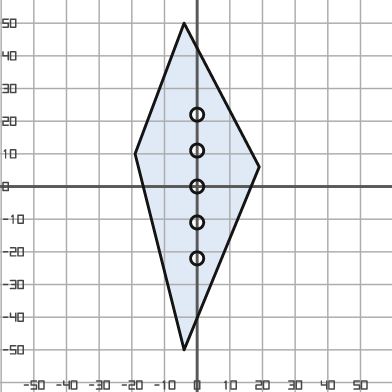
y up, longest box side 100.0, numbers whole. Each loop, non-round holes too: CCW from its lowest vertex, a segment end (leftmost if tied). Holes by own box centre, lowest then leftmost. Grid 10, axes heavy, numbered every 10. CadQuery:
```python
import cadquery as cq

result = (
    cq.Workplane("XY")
    .moveTo(-4.0, -50.0)
    .lineTo(19.0, 6.0)
    .lineTo(-4.0, 50.0)
    .lineTo(-19.0, 10.0)
    .close()
    .moveTo(0.0, -22.0)
    .circle(2.0)
    .moveTo(0.0, -11.0)
    .circle(2.0)
    .moveTo(0.0, 0.0)
    .circle(2.0)
    .moveTo(0.0, 11.0)
    .circle(2.0)
    .moveTo(0.0, 22.0)
    .circle(2.0)
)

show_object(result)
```